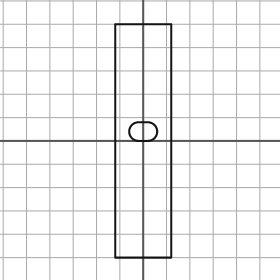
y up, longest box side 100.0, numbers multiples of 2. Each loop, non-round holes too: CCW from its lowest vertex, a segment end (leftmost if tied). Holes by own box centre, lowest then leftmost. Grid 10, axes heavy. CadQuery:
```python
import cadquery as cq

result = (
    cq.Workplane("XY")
    .moveTo(-12.0, -50.0)
    .lineTo(12.0, -50.0)
    .lineTo(12.0, 50.0)
    .lineTo(-12.0, 50.0)
    .close()
    .moveTo(-2.0, 0.0)
    .lineTo(2.0, 0.0)
    .threePointArc((6.0, 4.0), (2.0, 8.0))
    .lineTo(-2.0, 8.0)
    .threePointArc((-6.0, 4.0), (-2.0, 0.0))
    .close()
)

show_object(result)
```